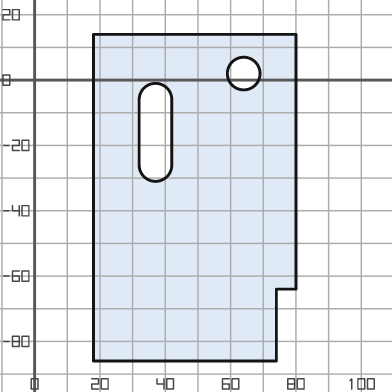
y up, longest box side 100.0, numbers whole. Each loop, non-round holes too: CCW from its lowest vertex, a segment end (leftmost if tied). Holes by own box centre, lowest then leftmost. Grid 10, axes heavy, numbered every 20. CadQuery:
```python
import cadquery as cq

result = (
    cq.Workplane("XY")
    .moveTo(18.0, -86.0)
    .lineTo(74.0, -86.0)
    .lineTo(74.0, -64.0)
    .lineTo(80.0, -64.0)
    .lineTo(80.0, 14.0)
    .lineTo(18.0, 14.0)
    .close()
    .moveTo(32.0, -26.0)
    .threePointArc((37.0, -31.0), (42.0, -26.0))
    .lineTo(42.0, -6.0)
    .threePointArc((37.0, -1.0), (32.0, -6.0))
    .close()
    .moveTo(64.0, 2.0)
    .circle(5.0)
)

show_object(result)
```